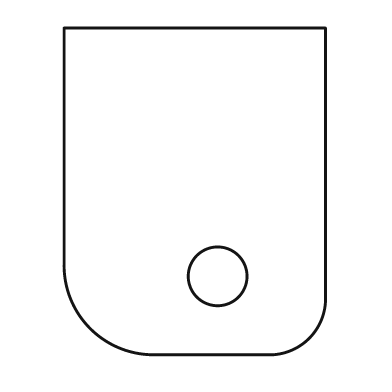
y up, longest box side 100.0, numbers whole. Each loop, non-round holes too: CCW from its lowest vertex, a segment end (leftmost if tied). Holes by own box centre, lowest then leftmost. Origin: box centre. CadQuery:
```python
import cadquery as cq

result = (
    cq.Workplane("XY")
    .moveTo(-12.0, -50.0)
    .lineTo(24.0, -50.0)
    .threePointArc((35.0, -45.0), (40.0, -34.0))
    .lineTo(40.0, 50.0)
    .lineTo(-40.0, 50.0)
    .lineTo(-40.0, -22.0)
    .threePointArc((-32.0, -42.0), (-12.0, -50.0))
    .close()
    .moveTo(7.0, -26.0)
    .circle(9.0)
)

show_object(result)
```